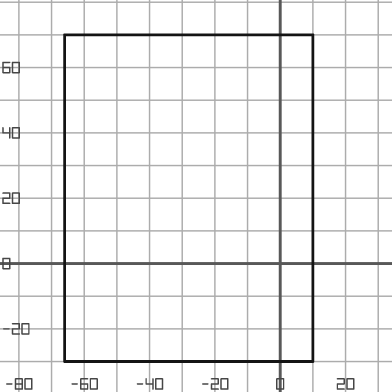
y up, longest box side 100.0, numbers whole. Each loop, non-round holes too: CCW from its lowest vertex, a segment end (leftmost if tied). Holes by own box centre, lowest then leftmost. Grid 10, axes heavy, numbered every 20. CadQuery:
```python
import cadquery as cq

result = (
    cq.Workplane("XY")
    .moveTo(-66.0, -30.0)
    .lineTo(10.0, -30.0)
    .lineTo(10.0, 70.0)
    .lineTo(-66.0, 70.0)
    .close()
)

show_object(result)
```